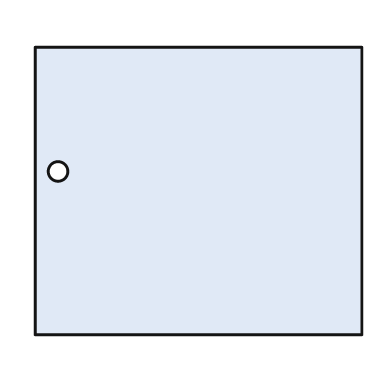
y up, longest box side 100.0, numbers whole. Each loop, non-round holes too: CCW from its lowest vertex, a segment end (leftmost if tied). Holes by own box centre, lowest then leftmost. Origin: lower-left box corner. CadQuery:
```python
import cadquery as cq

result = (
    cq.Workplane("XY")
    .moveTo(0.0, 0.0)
    .lineTo(100.0, 0.0)
    .lineTo(100.0, 88.0)
    .lineTo(0.0, 88.0)
    .close()
    .moveTo(7.0, 50.0)
    .circle(3.0)
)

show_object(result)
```